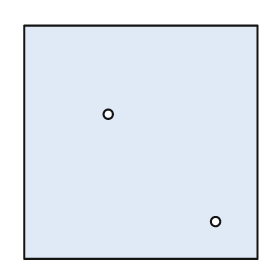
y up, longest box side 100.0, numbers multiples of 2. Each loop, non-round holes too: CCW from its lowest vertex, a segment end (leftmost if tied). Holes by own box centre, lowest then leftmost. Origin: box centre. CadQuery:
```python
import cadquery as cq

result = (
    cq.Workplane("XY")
    .moveTo(-50.0, -50.0)
    .lineTo(50.0, -50.0)
    .lineTo(50.0, 50.0)
    .lineTo(-50.0, 50.0)
    .close()
    .moveTo(32.0, -34.0)
    .circle(2.0)
    .moveTo(-14.0, 12.0)
    .circle(2.0)
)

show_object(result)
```